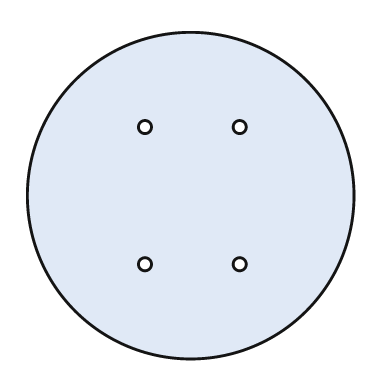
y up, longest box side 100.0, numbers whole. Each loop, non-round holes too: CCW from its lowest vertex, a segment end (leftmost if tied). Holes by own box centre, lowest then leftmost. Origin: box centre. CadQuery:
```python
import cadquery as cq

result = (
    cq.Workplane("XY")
    .moveTo(0.0, 0.0)
    .circle(50.0)
    .moveTo(-14.0, -21.0)
    .circle(2.0)
    .moveTo(15.0, -21.0)
    .circle(2.0)
    .moveTo(-14.0, 21.0)
    .circle(2.0)
    .moveTo(15.0, 21.0)
    .circle(2.0)
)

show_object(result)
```